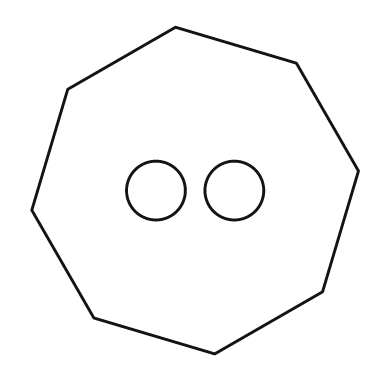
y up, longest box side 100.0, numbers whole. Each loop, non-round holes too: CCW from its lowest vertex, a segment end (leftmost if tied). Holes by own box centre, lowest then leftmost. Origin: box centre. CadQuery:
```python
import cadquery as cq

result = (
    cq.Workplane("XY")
    .moveTo(6.0, -50.0)
    .lineTo(39.0, -31.0)
    .lineTo(50.0, 6.0)
    .lineTo(31.0, 39.0)
    .lineTo(-6.0, 50.0)
    .lineTo(-39.0, 31.0)
    .lineTo(-50.0, -6.0)
    .lineTo(-31.0, -39.0)
    .close()
    .moveTo(-12.0, 0.0)
    .circle(9.0)
    .moveTo(12.0, 0.0)
    .circle(9.0)
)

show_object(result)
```